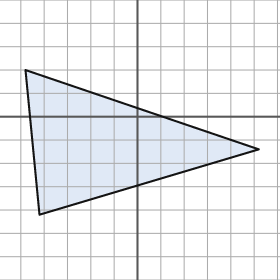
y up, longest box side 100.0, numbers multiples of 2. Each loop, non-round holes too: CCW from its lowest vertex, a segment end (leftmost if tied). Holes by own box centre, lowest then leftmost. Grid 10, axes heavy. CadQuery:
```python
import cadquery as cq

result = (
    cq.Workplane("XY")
    .moveTo(-42.0, -42.0)
    .lineTo(52.0, -14.0)
    .lineTo(-48.0, 20.0)
    .close()
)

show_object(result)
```